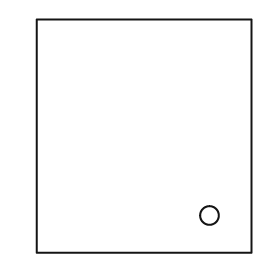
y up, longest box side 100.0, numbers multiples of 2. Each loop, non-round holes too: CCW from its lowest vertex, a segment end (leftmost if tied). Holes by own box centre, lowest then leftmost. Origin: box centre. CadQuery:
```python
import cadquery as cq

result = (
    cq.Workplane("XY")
    .moveTo(-46.0, -50.0)
    .lineTo(46.0, -50.0)
    .lineTo(46.0, 50.0)
    .lineTo(-46.0, 50.0)
    .close()
    .moveTo(28.0, -34.0)
    .circle(4.0)
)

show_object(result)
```